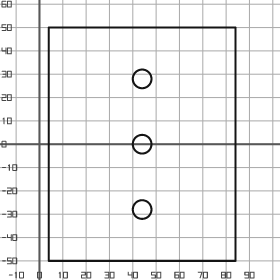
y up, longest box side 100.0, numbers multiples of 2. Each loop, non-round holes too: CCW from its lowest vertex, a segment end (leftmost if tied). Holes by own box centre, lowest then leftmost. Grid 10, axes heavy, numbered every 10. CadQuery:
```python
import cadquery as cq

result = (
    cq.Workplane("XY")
    .moveTo(4.0, -50.0)
    .lineTo(84.0, -50.0)
    .lineTo(84.0, 50.0)
    .lineTo(4.0, 50.0)
    .close()
    .moveTo(44.0, -28.0)
    .circle(4.0)
    .moveTo(44.0, 0.0)
    .circle(4.0)
    .moveTo(44.0, 28.0)
    .circle(4.0)
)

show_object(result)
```